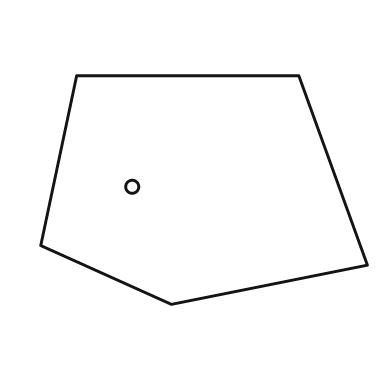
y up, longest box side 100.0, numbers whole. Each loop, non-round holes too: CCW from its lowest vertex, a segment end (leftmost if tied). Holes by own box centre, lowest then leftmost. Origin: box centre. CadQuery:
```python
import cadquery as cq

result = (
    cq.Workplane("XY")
    .moveTo(-10.0, -35.0)
    .lineTo(50.0, -23.0)
    .lineTo(29.0, 35.0)
    .lineTo(-39.0, 35.0)
    .lineTo(-50.0, -17.0)
    .close()
    .moveTo(-22.0, 1.0)
    .circle(2.0)
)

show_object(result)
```